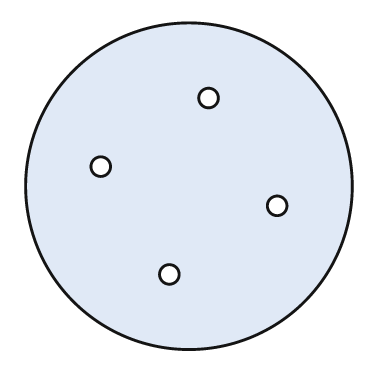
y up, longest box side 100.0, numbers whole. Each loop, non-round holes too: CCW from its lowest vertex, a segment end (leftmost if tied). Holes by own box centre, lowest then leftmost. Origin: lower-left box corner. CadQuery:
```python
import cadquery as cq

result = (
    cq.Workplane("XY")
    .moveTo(50.0, 50.0)
    .circle(50.0)
    .moveTo(44.0, 23.0)
    .circle(3.0)
    .moveTo(77.0, 44.0)
    .circle(3.0)
    .moveTo(23.0, 56.0)
    .circle(3.0)
    .moveTo(56.0, 77.0)
    .circle(3.0)
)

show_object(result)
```